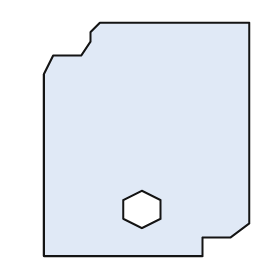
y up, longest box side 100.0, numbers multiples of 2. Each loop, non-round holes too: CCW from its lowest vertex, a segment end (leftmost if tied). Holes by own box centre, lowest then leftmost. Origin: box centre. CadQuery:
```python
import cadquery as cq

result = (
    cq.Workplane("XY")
    .moveTo(-44.0, -50.0)
    .lineTo(24.0, -50.0)
    .lineTo(24.0, -42.0)
    .lineTo(36.0, -42.0)
    .lineTo(44.0, -36.0)
    .lineTo(44.0, 50.0)
    .lineTo(-20.0, 50.0)
    .lineTo(-24.0, 46.0)
    .lineTo(-24.0, 42.0)
    .lineTo(-28.0, 36.0)
    .lineTo(-40.0, 36.0)
    .lineTo(-44.0, 28.0)
    .close()
    .moveTo(-2.0, -38.0)
    .lineTo(6.0, -34.0)
    .lineTo(6.0, -26.0)
    .lineTo(-2.0, -22.0)
    .lineTo(-10.0, -26.0)
    .lineTo(-10.0, -34.0)
    .close()
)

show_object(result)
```